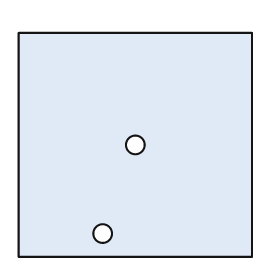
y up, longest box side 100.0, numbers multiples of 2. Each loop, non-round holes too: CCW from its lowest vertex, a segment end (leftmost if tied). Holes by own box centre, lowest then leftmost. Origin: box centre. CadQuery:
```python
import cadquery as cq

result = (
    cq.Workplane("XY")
    .moveTo(-50.0, -48.0)
    .lineTo(50.0, -48.0)
    .lineTo(50.0, 48.0)
    .lineTo(-50.0, 48.0)
    .close()
    .moveTo(-14.0, -38.0)
    .circle(4.0)
    .moveTo(0.0, 0.0)
    .circle(4.0)
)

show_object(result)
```